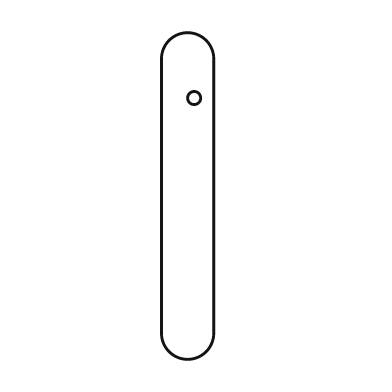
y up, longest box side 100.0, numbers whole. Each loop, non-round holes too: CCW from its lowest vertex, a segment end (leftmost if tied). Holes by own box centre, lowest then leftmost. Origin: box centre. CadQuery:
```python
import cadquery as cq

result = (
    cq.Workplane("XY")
    .moveTo(-8.0, -42.0)
    .threePointArc((0.0, -50.0), (8.0, -42.0))
    .lineTo(8.0, 42.0)
    .threePointArc((0.0, 50.0), (-8.0, 42.0))
    .close()
    .moveTo(2.0, 30.0)
    .circle(2.0)
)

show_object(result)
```